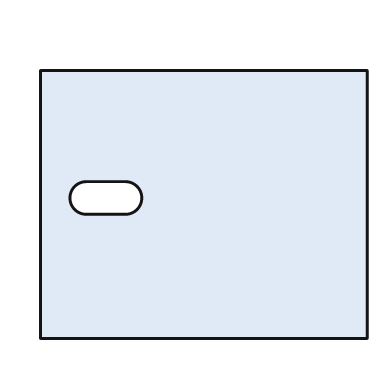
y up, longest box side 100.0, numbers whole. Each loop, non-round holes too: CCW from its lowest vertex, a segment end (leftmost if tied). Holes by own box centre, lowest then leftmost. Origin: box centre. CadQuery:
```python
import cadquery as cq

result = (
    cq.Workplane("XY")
    .moveTo(-50.0, -41.0)
    .lineTo(50.0, -41.0)
    .lineTo(50.0, 41.0)
    .lineTo(-50.0, 41.0)
    .close()
    .moveTo(-36.0, -3.0)
    .lineTo(-24.0, -3.0)
    .threePointArc((-19.0, 2.0), (-24.0, 7.0))
    .lineTo(-36.0, 7.0)
    .threePointArc((-41.0, 2.0), (-36.0, -3.0))
    .close()
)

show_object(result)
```